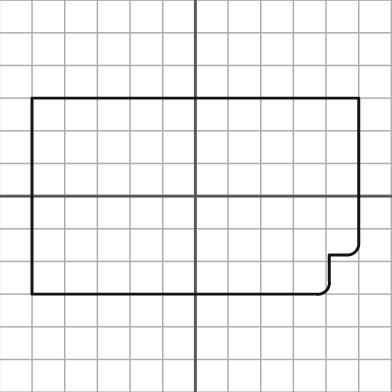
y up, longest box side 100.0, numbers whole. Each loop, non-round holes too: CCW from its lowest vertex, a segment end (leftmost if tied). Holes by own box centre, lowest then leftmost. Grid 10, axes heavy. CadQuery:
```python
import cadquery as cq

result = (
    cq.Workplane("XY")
    .moveTo(-50.0, -30.0)
    .lineTo(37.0, -30.0)
    .threePointArc((40.0, -29.0), (41.0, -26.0))
    .lineTo(41.0, -18.0)
    .lineTo(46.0, -18.0)
    .threePointArc((49.0, -17.0), (50.0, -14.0))
    .lineTo(50.0, 30.0)
    .lineTo(-50.0, 30.0)
    .close()
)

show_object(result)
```